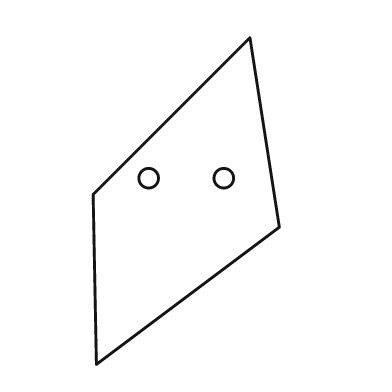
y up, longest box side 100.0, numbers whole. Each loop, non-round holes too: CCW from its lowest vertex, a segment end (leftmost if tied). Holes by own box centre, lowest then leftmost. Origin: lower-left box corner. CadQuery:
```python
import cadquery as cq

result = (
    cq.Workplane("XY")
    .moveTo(1.0, 0.0)
    .lineTo(57.0, 42.0)
    .lineTo(48.0, 100.0)
    .lineTo(0.0, 52.0)
    .close()
    .moveTo(17.0, 57.0)
    .circle(3.0)
    .moveTo(40.0, 57.0)
    .circle(3.0)
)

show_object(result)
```